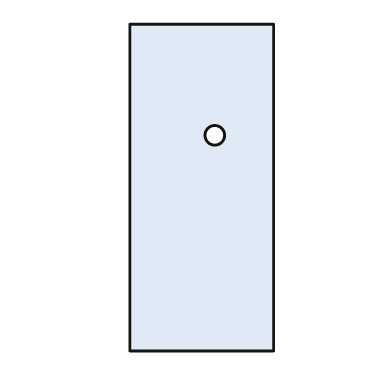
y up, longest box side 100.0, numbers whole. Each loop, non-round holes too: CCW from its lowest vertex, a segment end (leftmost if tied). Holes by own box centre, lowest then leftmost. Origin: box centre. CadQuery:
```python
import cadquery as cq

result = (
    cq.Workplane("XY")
    .moveTo(-22.0, -50.0)
    .lineTo(22.0, -50.0)
    .lineTo(22.0, 50.0)
    .lineTo(-22.0, 50.0)
    .close()
    .moveTo(4.0, 16.0)
    .circle(3.0)
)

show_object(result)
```